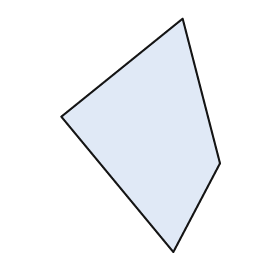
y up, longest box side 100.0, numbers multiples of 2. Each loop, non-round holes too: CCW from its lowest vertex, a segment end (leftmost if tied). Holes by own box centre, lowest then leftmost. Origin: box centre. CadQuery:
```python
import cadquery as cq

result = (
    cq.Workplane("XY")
    .moveTo(14.0, -50.0)
    .lineTo(34.0, -12.0)
    .lineTo(18.0, 50.0)
    .lineTo(-34.0, 8.0)
    .close()
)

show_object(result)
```